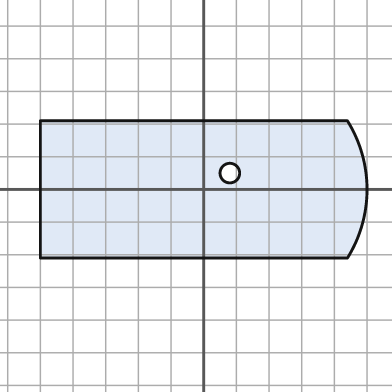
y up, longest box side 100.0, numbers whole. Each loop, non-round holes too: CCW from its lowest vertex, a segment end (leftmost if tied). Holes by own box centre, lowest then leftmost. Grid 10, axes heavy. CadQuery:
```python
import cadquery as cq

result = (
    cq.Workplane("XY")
    .moveTo(-50.0, -21.0)
    .lineTo(44.0, -21.0)
    .threePointArc((50.0, 0.0), (44.0, 21.0))
    .lineTo(-50.0, 21.0)
    .close()
    .moveTo(8.0, 5.0)
    .circle(3.0)
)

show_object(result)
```